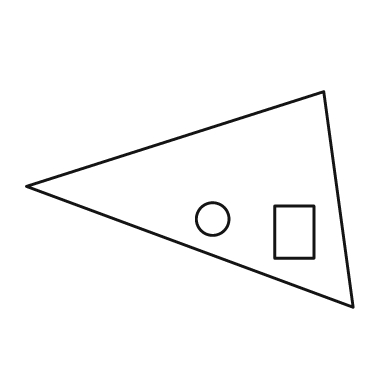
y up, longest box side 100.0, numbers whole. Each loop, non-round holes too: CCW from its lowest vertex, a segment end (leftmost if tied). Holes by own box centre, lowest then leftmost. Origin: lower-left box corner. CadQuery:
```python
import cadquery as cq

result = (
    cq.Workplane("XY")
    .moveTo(100.0, 0.0)
    .lineTo(91.0, 66.0)
    .lineTo(0.0, 37.0)
    .close()
    .moveTo(76.0, 15.0)
    .lineTo(88.0, 15.0)
    .lineTo(88.0, 31.0)
    .lineTo(76.0, 31.0)
    .close()
    .moveTo(57.0, 27.0)
    .circle(5.0)
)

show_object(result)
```